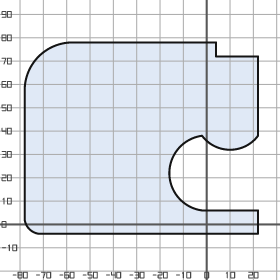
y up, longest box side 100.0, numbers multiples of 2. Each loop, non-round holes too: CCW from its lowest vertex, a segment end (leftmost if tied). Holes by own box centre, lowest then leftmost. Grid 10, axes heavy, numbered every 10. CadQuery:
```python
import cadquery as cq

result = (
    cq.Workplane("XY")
    .moveTo(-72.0, -4.0)
    .lineTo(22.0, -4.0)
    .lineTo(22.0, 6.0)
    .lineTo(-2.0, 6.0)
    .threePointArc((-16.0, 22.0), (-2.0, 38.0))
    .threePointArc((10.0, 32.0), (22.0, 38.0))
    .lineTo(22.0, 72.0)
    .lineTo(4.0, 72.0)
    .lineTo(4.0, 78.0)
    .lineTo(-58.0, 78.0)
    .threePointArc((-72.0, 72.0), (-78.0, 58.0))
    .lineTo(-78.0, 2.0)
    .threePointArc((-76.0, -2.0), (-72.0, -4.0))
    .close()
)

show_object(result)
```